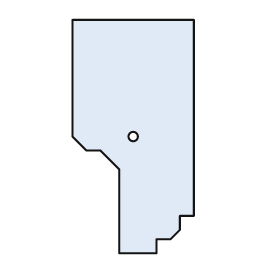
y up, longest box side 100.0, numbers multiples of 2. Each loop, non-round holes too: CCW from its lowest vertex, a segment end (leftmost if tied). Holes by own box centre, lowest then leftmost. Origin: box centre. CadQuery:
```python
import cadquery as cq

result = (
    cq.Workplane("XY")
    .moveTo(-6.0, -50.0)
    .lineTo(10.0, -50.0)
    .lineTo(10.0, -44.0)
    .lineTo(16.0, -44.0)
    .lineTo(20.0, -40.0)
    .lineTo(20.0, -34.0)
    .lineTo(26.0, -34.0)
    .lineTo(26.0, 50.0)
    .lineTo(-26.0, 50.0)
    .lineTo(-26.0, 0.0)
    .lineTo(-20.0, -6.0)
    .lineTo(-14.0, -6.0)
    .lineTo(-6.0, -14.0)
    .close()
    .moveTo(0.0, 0.0)
    .circle(2.0)
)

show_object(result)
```